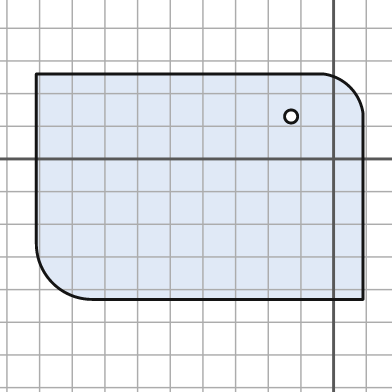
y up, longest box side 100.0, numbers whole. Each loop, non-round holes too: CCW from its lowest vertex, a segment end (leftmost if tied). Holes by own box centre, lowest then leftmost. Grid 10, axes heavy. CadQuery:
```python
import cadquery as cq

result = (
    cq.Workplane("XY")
    .moveTo(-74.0, -43.0)
    .lineTo(9.0, -43.0)
    .lineTo(9.0, 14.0)
    .threePointArc((5.0, 22.0), (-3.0, 26.0))
    .lineTo(-91.0, 26.0)
    .lineTo(-91.0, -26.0)
    .threePointArc((-86.0, -38.0), (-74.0, -43.0))
    .close()
    .moveTo(-13.0, 13.0)
    .circle(2.0)
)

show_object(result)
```